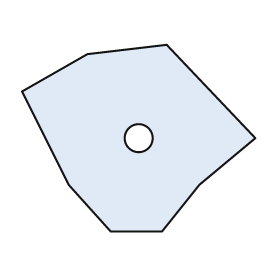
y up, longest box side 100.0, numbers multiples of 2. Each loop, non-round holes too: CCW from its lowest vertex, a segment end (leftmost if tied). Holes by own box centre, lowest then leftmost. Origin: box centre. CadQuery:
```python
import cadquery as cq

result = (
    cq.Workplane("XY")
    .moveTo(-12.0, -40.0)
    .lineTo(10.0, -40.0)
    .lineTo(26.0, -20.0)
    .lineTo(50.0, 0.0)
    .lineTo(12.0, 40.0)
    .lineTo(-22.0, 36.0)
    .lineTo(-50.0, 20.0)
    .lineTo(-30.0, -20.0)
    .close()
    .moveTo(0.0, 0.0)
    .circle(6.0)
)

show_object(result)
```